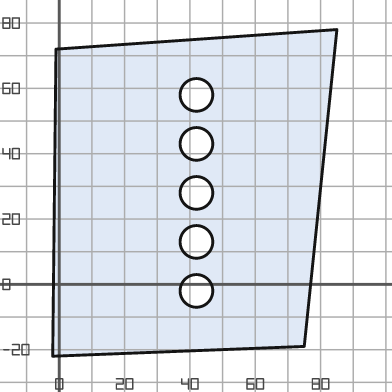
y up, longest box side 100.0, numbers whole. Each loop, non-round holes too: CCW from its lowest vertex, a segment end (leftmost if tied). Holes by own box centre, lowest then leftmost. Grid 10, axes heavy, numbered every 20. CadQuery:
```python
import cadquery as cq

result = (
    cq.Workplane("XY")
    .moveTo(-2.0, -22.0)
    .lineTo(75.0, -19.0)
    .lineTo(85.0, 78.0)
    .lineTo(-1.0, 72.0)
    .close()
    .moveTo(42.0, -2.0)
    .circle(5.0)
    .moveTo(42.0, 13.0)
    .circle(5.0)
    .moveTo(42.0, 28.0)
    .circle(5.0)
    .moveTo(42.0, 43.0)
    .circle(5.0)
    .moveTo(42.0, 58.0)
    .circle(5.0)
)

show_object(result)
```